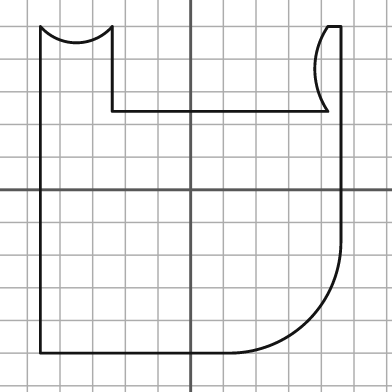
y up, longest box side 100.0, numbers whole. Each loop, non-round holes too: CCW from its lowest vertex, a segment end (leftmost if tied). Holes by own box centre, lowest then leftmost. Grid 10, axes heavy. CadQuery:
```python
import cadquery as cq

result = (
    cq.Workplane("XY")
    .moveTo(-46.0, -50.0)
    .lineTo(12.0, -50.0)
    .threePointArc((36.0, -40.0), (46.0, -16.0))
    .lineTo(46.0, 50.0)
    .lineTo(42.0, 50.0)
    .threePointArc((38.0, 37.0), (42.0, 24.0))
    .lineTo(-24.0, 24.0)
    .lineTo(-24.0, 50.0)
    .threePointArc((-35.0, 45.0), (-46.0, 50.0))
    .close()
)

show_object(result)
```